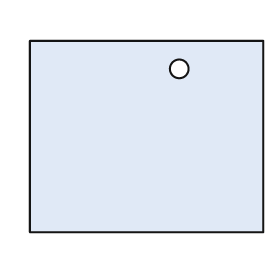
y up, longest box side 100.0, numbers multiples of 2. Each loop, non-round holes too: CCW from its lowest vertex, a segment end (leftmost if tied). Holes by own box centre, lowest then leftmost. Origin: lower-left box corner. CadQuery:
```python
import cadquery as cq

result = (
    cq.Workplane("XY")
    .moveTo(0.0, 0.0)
    .lineTo(100.0, 0.0)
    .lineTo(100.0, 82.0)
    .lineTo(0.0, 82.0)
    .close()
    .moveTo(64.0, 70.0)
    .circle(4.0)
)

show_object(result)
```